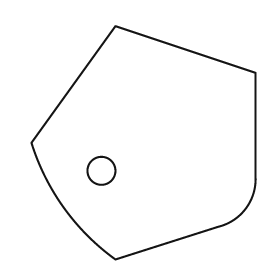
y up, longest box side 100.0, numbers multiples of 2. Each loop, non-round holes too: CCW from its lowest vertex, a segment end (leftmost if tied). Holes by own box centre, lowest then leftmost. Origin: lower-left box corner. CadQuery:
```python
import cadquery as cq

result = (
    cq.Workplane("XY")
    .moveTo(36.0, 0.0)
    .lineTo(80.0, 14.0)
    .threePointArc((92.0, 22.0), (96.0, 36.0))
    .lineTo(96.0, 80.0)
    .lineTo(36.0, 100.0)
    .lineTo(0.0, 50.0)
    .threePointArc((14.0, 22.0), (36.0, 0.0))
    .close()
    .moveTo(30.0, 38.0)
    .circle(6.0)
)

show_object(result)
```